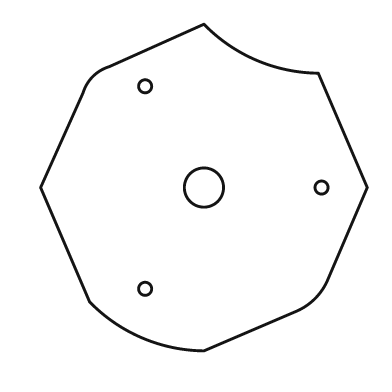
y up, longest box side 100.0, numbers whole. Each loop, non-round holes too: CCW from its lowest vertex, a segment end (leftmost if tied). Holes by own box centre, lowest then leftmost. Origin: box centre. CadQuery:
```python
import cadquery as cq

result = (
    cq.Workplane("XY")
    .moveTo(0.0, -50.0)
    .lineTo(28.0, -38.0)
    .threePointArc((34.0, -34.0), (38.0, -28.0))
    .lineTo(50.0, 0.0)
    .lineTo(35.0, 35.0)
    .threePointArc((16.0, 39.0), (0.0, 50.0))
    .lineTo(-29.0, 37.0)
    .threePointArc((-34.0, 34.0), (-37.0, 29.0))
    .lineTo(-50.0, 0.0)
    .lineTo(-35.0, -35.0)
    .threePointArc((-19.0, -46.0), (0.0, -50.0))
    .close()
    .moveTo(-18.0, -31.0)
    .circle(2.0)
    .moveTo(0.0, 0.0)
    .circle(6.0)
    .moveTo(36.0, 0.0)
    .circle(2.0)
    .moveTo(-18.0, 31.0)
    .circle(2.0)
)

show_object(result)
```